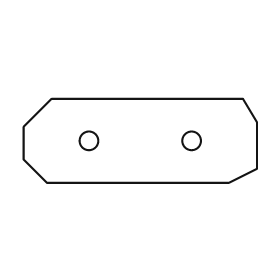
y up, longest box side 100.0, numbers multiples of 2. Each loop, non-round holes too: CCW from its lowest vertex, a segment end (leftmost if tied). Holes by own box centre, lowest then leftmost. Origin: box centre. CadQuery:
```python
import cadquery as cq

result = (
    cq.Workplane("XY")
    .moveTo(-40.0, -18.0)
    .lineTo(38.0, -18.0)
    .lineTo(50.0, -12.0)
    .lineTo(50.0, 8.0)
    .lineTo(44.0, 18.0)
    .lineTo(-38.0, 18.0)
    .lineTo(-50.0, 6.0)
    .lineTo(-50.0, -8.0)
    .close()
    .moveTo(-22.0, 0.0)
    .circle(4.0)
    .moveTo(22.0, 0.0)
    .circle(4.0)
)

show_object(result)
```